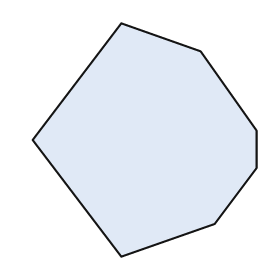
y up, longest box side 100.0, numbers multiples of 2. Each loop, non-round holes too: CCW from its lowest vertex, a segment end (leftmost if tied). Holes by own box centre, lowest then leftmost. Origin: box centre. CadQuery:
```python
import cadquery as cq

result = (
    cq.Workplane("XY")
    .moveTo(-10.0, -50.0)
    .lineTo(30.0, -36.0)
    .lineTo(48.0, -12.0)
    .lineTo(48.0, 4.0)
    .lineTo(24.0, 38.0)
    .lineTo(-10.0, 50.0)
    .lineTo(-48.0, 0.0)
    .close()
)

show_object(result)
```